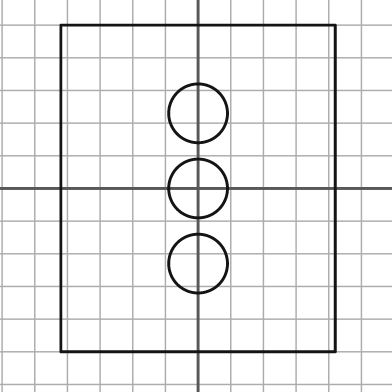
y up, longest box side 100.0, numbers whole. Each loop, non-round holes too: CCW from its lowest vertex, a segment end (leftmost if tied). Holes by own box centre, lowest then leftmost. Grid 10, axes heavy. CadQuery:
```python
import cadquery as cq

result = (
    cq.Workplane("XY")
    .moveTo(-42.0, -50.0)
    .lineTo(42.0, -50.0)
    .lineTo(42.0, 50.0)
    .lineTo(-42.0, 50.0)
    .close()
    .moveTo(0.0, -23.0)
    .circle(9.0)
    .moveTo(0.0, 0.0)
    .circle(9.0)
    .moveTo(0.0, 23.0)
    .circle(9.0)
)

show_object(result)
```